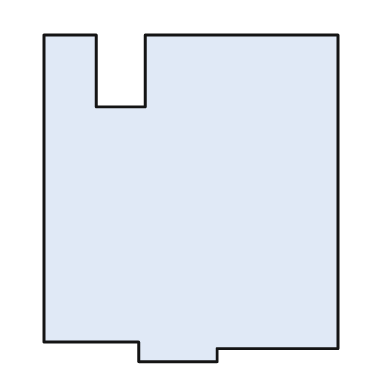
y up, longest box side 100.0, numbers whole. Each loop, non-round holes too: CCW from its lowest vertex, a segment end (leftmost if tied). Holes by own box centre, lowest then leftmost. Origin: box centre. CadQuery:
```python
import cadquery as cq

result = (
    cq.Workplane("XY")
    .moveTo(-16.0, -50.0)
    .lineTo(8.0, -50.0)
    .lineTo(8.0, -46.0)
    .lineTo(45.0, -46.0)
    .lineTo(45.0, 50.0)
    .lineTo(-14.0, 50.0)
    .lineTo(-14.0, 28.0)
    .lineTo(-29.0, 28.0)
    .lineTo(-29.0, 50.0)
    .lineTo(-45.0, 50.0)
    .lineTo(-45.0, -44.0)
    .lineTo(-16.0, -44.0)
    .close()
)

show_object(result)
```